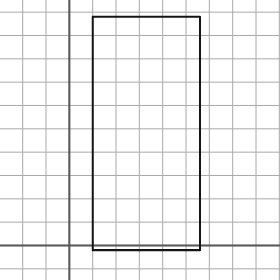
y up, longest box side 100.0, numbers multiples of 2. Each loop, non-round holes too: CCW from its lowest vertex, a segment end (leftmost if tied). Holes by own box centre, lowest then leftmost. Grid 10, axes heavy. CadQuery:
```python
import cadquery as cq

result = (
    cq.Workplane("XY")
    .moveTo(10.0, -2.0)
    .lineTo(56.0, -2.0)
    .lineTo(56.0, 98.0)
    .lineTo(10.0, 98.0)
    .close()
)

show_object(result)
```